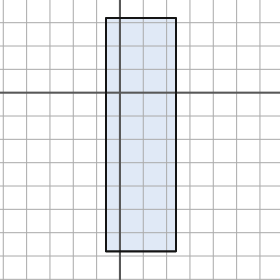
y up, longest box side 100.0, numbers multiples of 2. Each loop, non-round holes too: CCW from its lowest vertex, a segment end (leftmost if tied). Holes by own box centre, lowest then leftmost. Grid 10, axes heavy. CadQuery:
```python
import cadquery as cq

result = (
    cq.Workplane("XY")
    .moveTo(-6.0, -68.0)
    .lineTo(24.0, -68.0)
    .lineTo(24.0, 32.0)
    .lineTo(-6.0, 32.0)
    .close()
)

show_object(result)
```